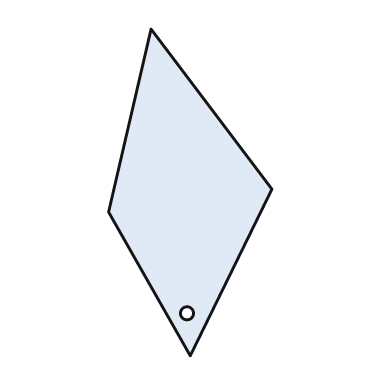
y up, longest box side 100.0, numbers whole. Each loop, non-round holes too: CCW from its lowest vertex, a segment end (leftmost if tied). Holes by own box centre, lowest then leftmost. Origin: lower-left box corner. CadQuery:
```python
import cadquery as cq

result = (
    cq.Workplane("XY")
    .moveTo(25.0, 0.0)
    .lineTo(50.0, 51.0)
    .lineTo(13.0, 100.0)
    .lineTo(0.0, 44.0)
    .close()
    .moveTo(24.0, 13.0)
    .circle(2.0)
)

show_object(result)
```